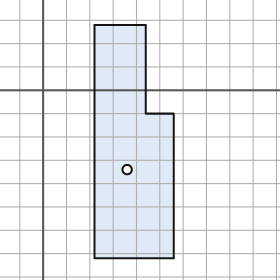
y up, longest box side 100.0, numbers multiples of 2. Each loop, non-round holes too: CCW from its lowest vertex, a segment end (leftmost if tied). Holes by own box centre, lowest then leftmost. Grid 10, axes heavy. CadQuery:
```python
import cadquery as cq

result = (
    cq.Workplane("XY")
    .moveTo(22.0, -72.0)
    .lineTo(56.0, -72.0)
    .lineTo(56.0, -10.0)
    .lineTo(44.0, -10.0)
    .lineTo(44.0, 28.0)
    .lineTo(22.0, 28.0)
    .close()
    .moveTo(36.0, -34.0)
    .circle(2.0)
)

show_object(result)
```